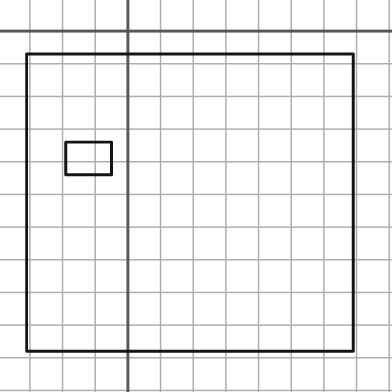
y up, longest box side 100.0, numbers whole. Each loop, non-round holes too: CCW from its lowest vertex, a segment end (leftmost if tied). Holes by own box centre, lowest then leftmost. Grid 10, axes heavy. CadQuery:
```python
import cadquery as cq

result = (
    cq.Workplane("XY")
    .moveTo(-31.0, -98.0)
    .lineTo(69.0, -98.0)
    .lineTo(69.0, -7.0)
    .lineTo(-31.0, -7.0)
    .close()
    .moveTo(-19.0, -44.0)
    .lineTo(-5.0, -44.0)
    .lineTo(-5.0, -34.0)
    .lineTo(-19.0, -34.0)
    .close()
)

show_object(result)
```